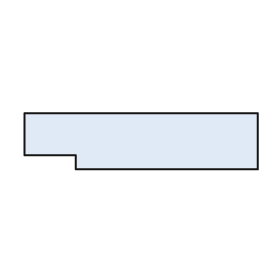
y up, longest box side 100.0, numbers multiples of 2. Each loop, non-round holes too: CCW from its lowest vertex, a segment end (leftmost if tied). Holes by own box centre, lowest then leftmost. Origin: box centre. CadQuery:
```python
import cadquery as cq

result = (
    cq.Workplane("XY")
    .moveTo(-28.0, -12.0)
    .lineTo(50.0, -12.0)
    .lineTo(50.0, 12.0)
    .lineTo(-50.0, 12.0)
    .lineTo(-50.0, -6.0)
    .lineTo(-28.0, -6.0)
    .close()
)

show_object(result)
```